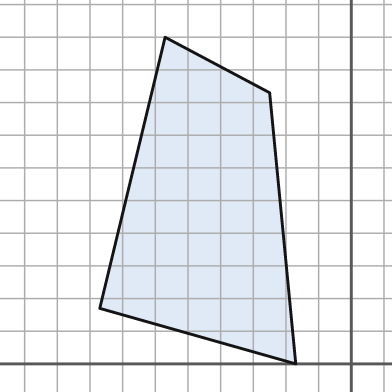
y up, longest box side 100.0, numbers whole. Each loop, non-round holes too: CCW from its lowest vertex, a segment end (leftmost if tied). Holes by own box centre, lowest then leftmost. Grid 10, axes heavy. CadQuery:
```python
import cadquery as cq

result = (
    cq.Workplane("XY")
    .moveTo(-17.0, 0.0)
    .lineTo(-25.0, 83.0)
    .lineTo(-57.0, 100.0)
    .lineTo(-77.0, 17.0)
    .close()
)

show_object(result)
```